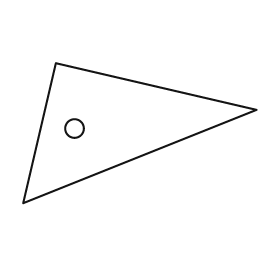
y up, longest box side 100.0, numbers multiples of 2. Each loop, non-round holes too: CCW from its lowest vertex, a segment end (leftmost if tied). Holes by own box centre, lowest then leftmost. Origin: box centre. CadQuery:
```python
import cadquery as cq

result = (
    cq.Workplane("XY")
    .moveTo(-50.0, -30.0)
    .lineTo(50.0, 10.0)
    .lineTo(-36.0, 30.0)
    .close()
    .moveTo(-28.0, 2.0)
    .circle(4.0)
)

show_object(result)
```